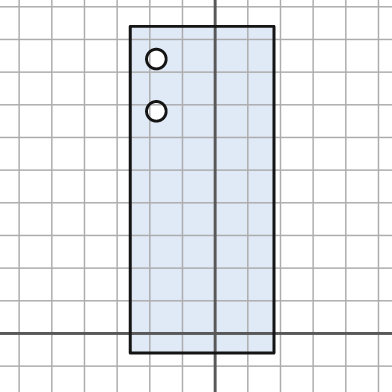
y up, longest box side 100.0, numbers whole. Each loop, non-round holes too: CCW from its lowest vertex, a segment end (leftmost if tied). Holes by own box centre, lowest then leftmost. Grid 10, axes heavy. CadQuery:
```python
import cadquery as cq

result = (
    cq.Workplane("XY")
    .moveTo(-26.0, -6.0)
    .lineTo(18.0, -6.0)
    .lineTo(18.0, 94.0)
    .lineTo(-26.0, 94.0)
    .close()
    .moveTo(-18.0, 68.0)
    .circle(3.0)
    .moveTo(-18.0, 84.0)
    .circle(3.0)
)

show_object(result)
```